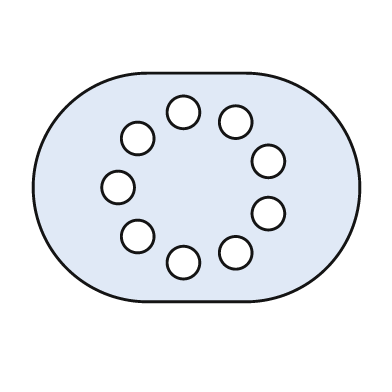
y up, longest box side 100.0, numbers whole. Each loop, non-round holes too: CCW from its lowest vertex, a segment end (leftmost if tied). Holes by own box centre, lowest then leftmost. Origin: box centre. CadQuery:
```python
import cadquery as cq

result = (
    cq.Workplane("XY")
    .moveTo(-15.0, -35.0)
    .lineTo(15.0, -35.0)
    .threePointArc((50.0, 0.0), (15.0, 35.0))
    .lineTo(-15.0, 35.0)
    .threePointArc((-50.0, 0.0), (-15.0, -35.0))
    .close()
    .moveTo(-4.0, -23.0)
    .circle(5.0)
    .moveTo(12.0, -20.0)
    .circle(5.0)
    .moveTo(-18.0, -15.0)
    .circle(5.0)
    .moveTo(22.0, -8.0)
    .circle(5.0)
    .moveTo(-24.0, 0.0)
    .circle(5.0)
    .moveTo(22.0, 8.0)
    .circle(5.0)
    .moveTo(-18.0, 15.0)
    .circle(5.0)
    .moveTo(12.0, 20.0)
    .circle(5.0)
    .moveTo(-4.0, 23.0)
    .circle(5.0)
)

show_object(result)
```